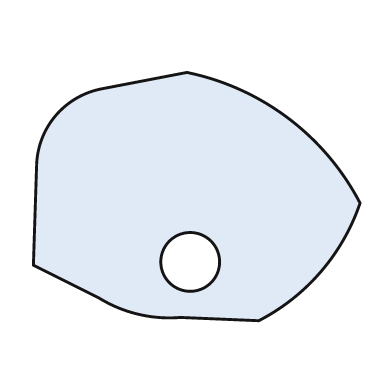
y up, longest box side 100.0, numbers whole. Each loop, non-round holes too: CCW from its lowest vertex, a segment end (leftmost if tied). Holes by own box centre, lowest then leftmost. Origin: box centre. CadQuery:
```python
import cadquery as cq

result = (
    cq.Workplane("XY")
    .moveTo(19.0, -38.0)
    .threePointArc((38.0, -23.0), (50.0, -2.0))
    .threePointArc((28.0, 24.0), (-3.0, 38.0))
    .lineTo(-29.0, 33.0)
    .threePointArc((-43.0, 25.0), (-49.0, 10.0))
    .lineTo(-50.0, -21.0)
    .lineTo(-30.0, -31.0)
    .threePointArc((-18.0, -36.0), (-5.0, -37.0))
    .close()
    .moveTo(-2.0, -20.0)
    .circle(9.0)
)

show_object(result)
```